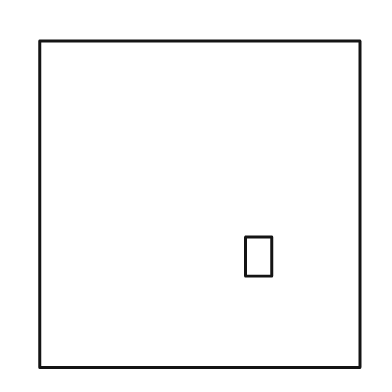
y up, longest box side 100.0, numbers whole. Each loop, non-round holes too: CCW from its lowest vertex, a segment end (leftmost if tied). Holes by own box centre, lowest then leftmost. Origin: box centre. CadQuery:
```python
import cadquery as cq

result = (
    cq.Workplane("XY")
    .moveTo(-49.0, -50.0)
    .lineTo(49.0, -50.0)
    .lineTo(49.0, 50.0)
    .lineTo(-49.0, 50.0)
    .close()
    .moveTo(14.0, -22.0)
    .lineTo(22.0, -22.0)
    .lineTo(22.0, -10.0)
    .lineTo(14.0, -10.0)
    .close()
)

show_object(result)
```